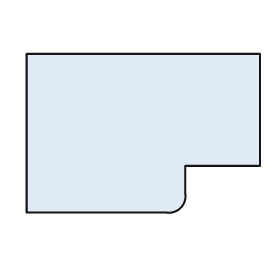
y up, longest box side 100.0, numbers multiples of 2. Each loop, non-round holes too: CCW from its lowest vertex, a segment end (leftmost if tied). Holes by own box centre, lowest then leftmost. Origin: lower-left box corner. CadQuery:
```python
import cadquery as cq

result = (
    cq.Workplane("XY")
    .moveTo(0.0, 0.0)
    .lineTo(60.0, 0.0)
    .threePointArc((66.0, 2.0), (68.0, 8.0))
    .lineTo(68.0, 20.0)
    .lineTo(100.0, 20.0)
    .lineTo(100.0, 68.0)
    .lineTo(0.0, 68.0)
    .close()
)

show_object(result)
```